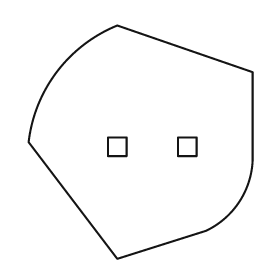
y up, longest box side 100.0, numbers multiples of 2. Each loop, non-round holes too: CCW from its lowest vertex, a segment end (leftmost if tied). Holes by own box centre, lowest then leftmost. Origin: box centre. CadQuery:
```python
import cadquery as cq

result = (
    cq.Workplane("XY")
    .moveTo(-10.0, -50.0)
    .lineTo(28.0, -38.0)
    .threePointArc((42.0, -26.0), (48.0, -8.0))
    .lineTo(48.0, 30.0)
    .lineTo(-10.0, 50.0)
    .threePointArc((-36.0, 30.0), (-48.0, 0.0))
    .close()
    .moveTo(-14.0, -6.0)
    .lineTo(-6.0, -6.0)
    .lineTo(-6.0, 2.0)
    .lineTo(-14.0, 2.0)
    .close()
    .moveTo(16.0, -6.0)
    .lineTo(24.0, -6.0)
    .lineTo(24.0, 2.0)
    .lineTo(16.0, 2.0)
    .close()
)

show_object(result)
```